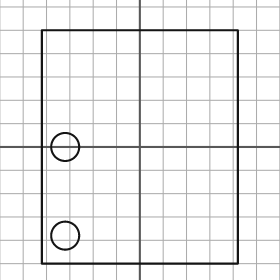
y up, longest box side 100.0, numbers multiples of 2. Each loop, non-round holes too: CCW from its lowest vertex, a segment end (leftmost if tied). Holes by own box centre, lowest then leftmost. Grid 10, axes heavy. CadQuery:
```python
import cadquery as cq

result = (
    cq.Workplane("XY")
    .moveTo(-42.0, -50.0)
    .lineTo(42.0, -50.0)
    .lineTo(42.0, 50.0)
    .lineTo(-42.0, 50.0)
    .close()
    .moveTo(-32.0, -38.0)
    .circle(6.0)
    .moveTo(-32.0, 0.0)
    .circle(6.0)
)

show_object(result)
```